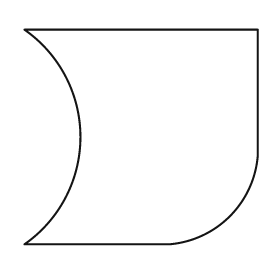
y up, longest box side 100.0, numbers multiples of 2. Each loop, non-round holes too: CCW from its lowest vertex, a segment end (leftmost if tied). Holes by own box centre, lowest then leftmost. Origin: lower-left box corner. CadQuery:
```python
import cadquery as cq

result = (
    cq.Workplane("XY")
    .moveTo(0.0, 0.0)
    .lineTo(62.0, 0.0)
    .threePointArc((88.0, 12.0), (100.0, 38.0))
    .lineTo(100.0, 92.0)
    .lineTo(0.0, 92.0)
    .threePointArc((24.0, 46.0), (0.0, 0.0))
    .close()
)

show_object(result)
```